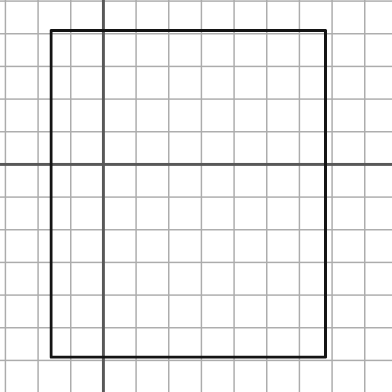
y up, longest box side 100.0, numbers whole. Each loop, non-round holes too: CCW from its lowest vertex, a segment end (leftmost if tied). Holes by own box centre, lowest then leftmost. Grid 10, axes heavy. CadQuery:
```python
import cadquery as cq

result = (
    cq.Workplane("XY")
    .moveTo(-16.0, -59.0)
    .lineTo(68.0, -59.0)
    .lineTo(68.0, 41.0)
    .lineTo(-16.0, 41.0)
    .close()
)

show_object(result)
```